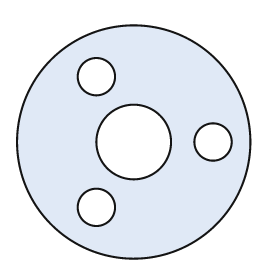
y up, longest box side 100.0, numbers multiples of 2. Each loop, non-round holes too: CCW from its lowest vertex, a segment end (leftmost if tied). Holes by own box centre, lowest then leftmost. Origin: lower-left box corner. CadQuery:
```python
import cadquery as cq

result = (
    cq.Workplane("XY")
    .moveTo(50.0, 50.0)
    .circle(50.0)
    .moveTo(34.0, 22.0)
    .circle(8.0)
    .moveTo(50.0, 50.0)
    .circle(16.0)
    .moveTo(84.0, 50.0)
    .circle(8.0)
    .moveTo(34.0, 78.0)
    .circle(8.0)
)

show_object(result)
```